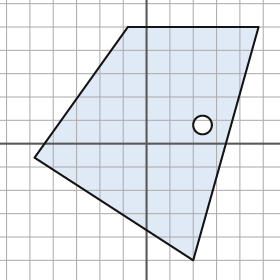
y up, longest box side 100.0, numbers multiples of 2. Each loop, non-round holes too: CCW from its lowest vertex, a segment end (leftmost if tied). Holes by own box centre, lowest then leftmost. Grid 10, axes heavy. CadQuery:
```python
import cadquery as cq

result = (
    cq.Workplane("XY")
    .moveTo(20.0, -50.0)
    .lineTo(48.0, 50.0)
    .lineTo(-8.0, 50.0)
    .lineTo(-48.0, -6.0)
    .close()
    .moveTo(24.0, 8.0)
    .circle(4.0)
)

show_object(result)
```